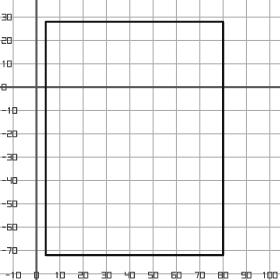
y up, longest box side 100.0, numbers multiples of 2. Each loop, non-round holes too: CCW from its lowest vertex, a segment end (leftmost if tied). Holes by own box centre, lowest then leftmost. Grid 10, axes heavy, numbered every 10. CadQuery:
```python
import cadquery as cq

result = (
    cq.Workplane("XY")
    .moveTo(4.0, -72.0)
    .lineTo(80.0, -72.0)
    .lineTo(80.0, 28.0)
    .lineTo(4.0, 28.0)
    .close()
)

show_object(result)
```